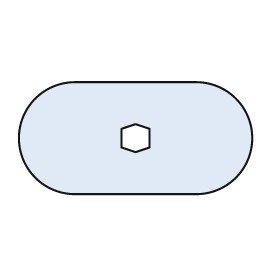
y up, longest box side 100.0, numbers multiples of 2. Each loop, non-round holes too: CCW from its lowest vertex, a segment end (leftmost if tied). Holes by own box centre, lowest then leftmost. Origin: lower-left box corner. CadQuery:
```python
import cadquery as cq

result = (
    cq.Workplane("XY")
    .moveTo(24.0, 0.0)
    .lineTo(76.0, 0.0)
    .threePointArc((100.0, 24.0), (76.0, 48.0))
    .lineTo(24.0, 48.0)
    .threePointArc((0.0, 24.0), (24.0, 0.0))
    .close()
    .moveTo(50.0, 18.0)
    .lineTo(56.0, 20.0)
    .lineTo(56.0, 28.0)
    .lineTo(50.0, 30.0)
    .lineTo(44.0, 28.0)
    .lineTo(44.0, 20.0)
    .close()
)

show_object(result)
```